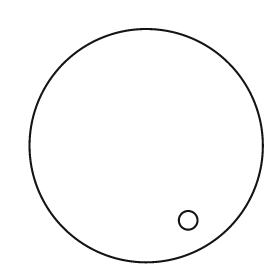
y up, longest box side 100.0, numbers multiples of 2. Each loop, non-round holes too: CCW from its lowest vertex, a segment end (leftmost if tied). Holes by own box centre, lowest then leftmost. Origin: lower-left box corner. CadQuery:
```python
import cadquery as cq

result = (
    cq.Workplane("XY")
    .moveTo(50.0, 50.0)
    .circle(50.0)
    .moveTo(68.0, 18.0)
    .circle(4.0)
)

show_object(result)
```